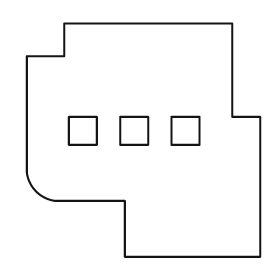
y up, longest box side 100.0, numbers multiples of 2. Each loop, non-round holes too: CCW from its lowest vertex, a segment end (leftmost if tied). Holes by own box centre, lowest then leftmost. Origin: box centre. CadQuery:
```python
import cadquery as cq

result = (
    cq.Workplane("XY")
    .moveTo(-8.0, -50.0)
    .lineTo(50.0, -50.0)
    .lineTo(50.0, 10.0)
    .lineTo(38.0, 10.0)
    .lineTo(38.0, 50.0)
    .lineTo(-34.0, 50.0)
    .lineTo(-34.0, 36.0)
    .lineTo(-50.0, 36.0)
    .lineTo(-50.0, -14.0)
    .threePointArc((-46.0, -22.0), (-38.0, -26.0))
    .lineTo(-8.0, -26.0)
    .close()
    .moveTo(-32.0, -2.0)
    .lineTo(-20.0, -2.0)
    .lineTo(-20.0, 10.0)
    .lineTo(-32.0, 10.0)
    .close()
    .moveTo(-10.0, -2.0)
    .lineTo(2.0, -2.0)
    .lineTo(2.0, 10.0)
    .lineTo(-10.0, 10.0)
    .close()
    .moveTo(12.0, -2.0)
    .lineTo(24.0, -2.0)
    .lineTo(24.0, 10.0)
    .lineTo(12.0, 10.0)
    .close()
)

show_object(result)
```